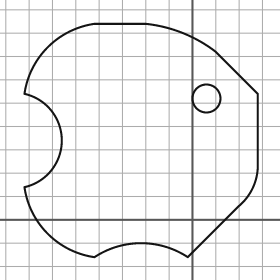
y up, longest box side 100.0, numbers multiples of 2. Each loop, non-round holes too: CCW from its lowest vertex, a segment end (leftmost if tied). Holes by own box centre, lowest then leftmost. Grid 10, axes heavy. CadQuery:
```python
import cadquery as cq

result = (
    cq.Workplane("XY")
    .moveTo(-42.0, -16.0)
    .threePointArc((-22.0, -10.0), (-2.0, -16.0))
    .lineTo(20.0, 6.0)
    .threePointArc((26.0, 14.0), (28.0, 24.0))
    .lineTo(28.0, 54.0)
    .lineTo(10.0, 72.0)
    .threePointArc((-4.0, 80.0), (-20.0, 84.0))
    .lineTo(-42.0, 84.0)
    .threePointArc((-62.0, 74.0), (-72.0, 54.0))
    .threePointArc((-56.0, 34.0), (-72.0, 14.0))
    .threePointArc((-62.0, -6.0), (-42.0, -16.0))
    .close()
    .moveTo(6.0, 52.0)
    .circle(6.0)
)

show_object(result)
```